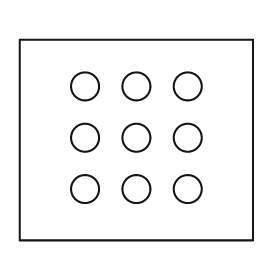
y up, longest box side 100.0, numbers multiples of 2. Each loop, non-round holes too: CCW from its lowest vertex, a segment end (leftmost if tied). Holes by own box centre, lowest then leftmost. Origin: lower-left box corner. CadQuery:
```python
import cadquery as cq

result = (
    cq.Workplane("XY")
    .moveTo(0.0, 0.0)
    .lineTo(100.0, 0.0)
    .lineTo(100.0, 86.0)
    .lineTo(0.0, 86.0)
    .close()
    .moveTo(28.0, 22.0)
    .circle(6.0)
    .moveTo(50.0, 22.0)
    .circle(6.0)
    .moveTo(72.0, 22.0)
    .circle(6.0)
    .moveTo(28.0, 44.0)
    .circle(6.0)
    .moveTo(50.0, 44.0)
    .circle(6.0)
    .moveTo(72.0, 44.0)
    .circle(6.0)
    .moveTo(28.0, 66.0)
    .circle(6.0)
    .moveTo(50.0, 66.0)
    .circle(6.0)
    .moveTo(72.0, 66.0)
    .circle(6.0)
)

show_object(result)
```